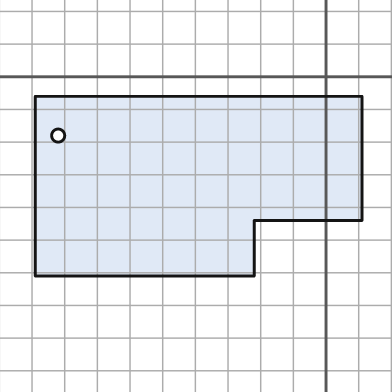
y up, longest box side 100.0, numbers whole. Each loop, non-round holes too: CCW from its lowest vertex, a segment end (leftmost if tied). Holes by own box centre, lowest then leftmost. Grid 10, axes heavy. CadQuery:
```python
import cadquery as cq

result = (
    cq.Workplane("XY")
    .moveTo(-89.0, -61.0)
    .lineTo(-22.0, -61.0)
    .lineTo(-22.0, -44.0)
    .lineTo(11.0, -44.0)
    .lineTo(11.0, -6.0)
    .lineTo(-89.0, -6.0)
    .close()
    .moveTo(-82.0, -18.0)
    .circle(2.0)
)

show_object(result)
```